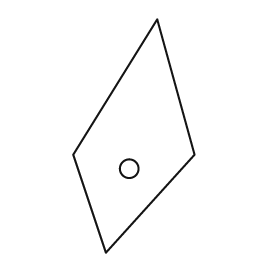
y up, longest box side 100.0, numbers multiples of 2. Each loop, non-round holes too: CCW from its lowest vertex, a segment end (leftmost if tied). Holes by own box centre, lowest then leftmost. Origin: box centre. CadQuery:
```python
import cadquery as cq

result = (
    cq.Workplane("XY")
    .moveTo(-12.0, -50.0)
    .lineTo(26.0, -8.0)
    .lineTo(10.0, 50.0)
    .lineTo(-26.0, -8.0)
    .close()
    .moveTo(-2.0, -14.0)
    .circle(4.0)
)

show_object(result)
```